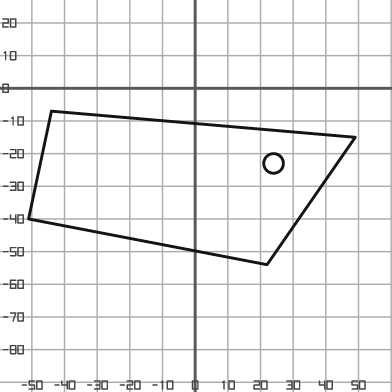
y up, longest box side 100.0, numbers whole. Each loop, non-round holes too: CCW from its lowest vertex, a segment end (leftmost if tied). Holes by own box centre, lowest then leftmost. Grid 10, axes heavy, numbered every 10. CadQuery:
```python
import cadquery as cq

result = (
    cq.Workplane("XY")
    .moveTo(22.0, -54.0)
    .lineTo(49.0, -15.0)
    .lineTo(-44.0, -7.0)
    .lineTo(-51.0, -40.0)
    .close()
    .moveTo(24.0, -23.0)
    .circle(3.0)
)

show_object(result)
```